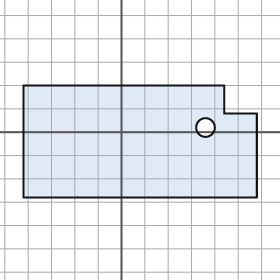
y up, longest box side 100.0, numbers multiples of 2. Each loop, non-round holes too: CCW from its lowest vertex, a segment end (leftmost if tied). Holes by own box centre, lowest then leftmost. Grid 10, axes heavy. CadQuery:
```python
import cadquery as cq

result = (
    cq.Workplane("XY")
    .moveTo(-42.0, -28.0)
    .lineTo(58.0, -28.0)
    .lineTo(58.0, 8.0)
    .lineTo(44.0, 8.0)
    .lineTo(44.0, 20.0)
    .lineTo(-42.0, 20.0)
    .close()
    .moveTo(36.0, 2.0)
    .circle(4.0)
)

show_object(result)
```